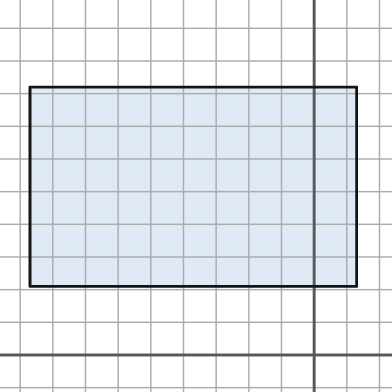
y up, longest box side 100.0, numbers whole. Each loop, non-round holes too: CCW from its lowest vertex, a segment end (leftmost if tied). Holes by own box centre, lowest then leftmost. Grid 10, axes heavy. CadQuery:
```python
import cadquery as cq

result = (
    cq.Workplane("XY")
    .moveTo(-87.0, 21.0)
    .lineTo(13.0, 21.0)
    .lineTo(13.0, 82.0)
    .lineTo(-87.0, 82.0)
    .close()
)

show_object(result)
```